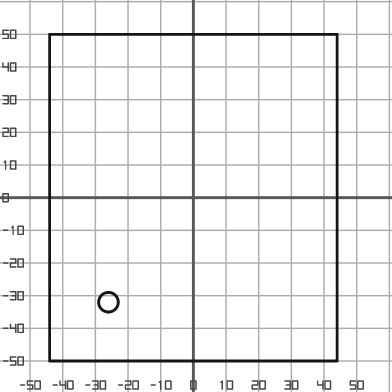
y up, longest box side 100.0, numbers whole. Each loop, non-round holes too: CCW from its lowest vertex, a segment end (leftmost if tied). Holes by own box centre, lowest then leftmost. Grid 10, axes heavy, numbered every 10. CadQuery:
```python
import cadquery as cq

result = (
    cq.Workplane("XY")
    .moveTo(-44.0, -50.0)
    .lineTo(44.0, -50.0)
    .lineTo(44.0, 50.0)
    .lineTo(-44.0, 50.0)
    .close()
    .moveTo(-26.0, -32.0)
    .circle(3.0)
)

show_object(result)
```